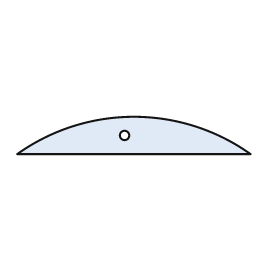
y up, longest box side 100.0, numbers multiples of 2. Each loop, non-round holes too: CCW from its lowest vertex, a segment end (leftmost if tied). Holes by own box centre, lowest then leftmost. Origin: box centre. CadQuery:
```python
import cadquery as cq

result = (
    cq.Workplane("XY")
    .moveTo(-50.0, -8.0)
    .lineTo(50.0, -8.0)
    .threePointArc((0.0, 8.0), (-50.0, -8.0))
    .close()
    .moveTo(-4.0, 0.0)
    .circle(2.0)
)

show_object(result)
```